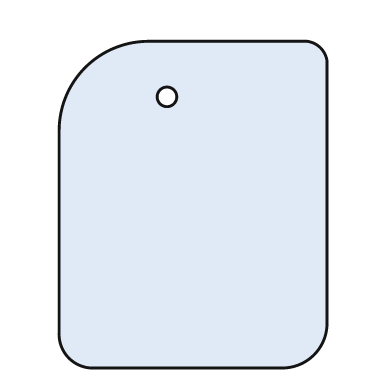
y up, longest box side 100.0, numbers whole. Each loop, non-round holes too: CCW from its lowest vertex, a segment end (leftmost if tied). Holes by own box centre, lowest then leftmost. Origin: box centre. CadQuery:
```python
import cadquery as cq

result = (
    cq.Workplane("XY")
    .moveTo(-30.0, -50.0)
    .lineTo(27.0, -50.0)
    .threePointArc((37.0, -46.0), (41.0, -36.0))
    .lineTo(41.0, 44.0)
    .threePointArc((39.0, 48.0), (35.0, 50.0))
    .lineTo(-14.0, 50.0)
    .threePointArc((-33.0, 42.0), (-41.0, 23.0))
    .lineTo(-41.0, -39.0)
    .threePointArc((-38.0, -47.0), (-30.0, -50.0))
    .close()
    .moveTo(-8.0, 33.0)
    .circle(3.0)
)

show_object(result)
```